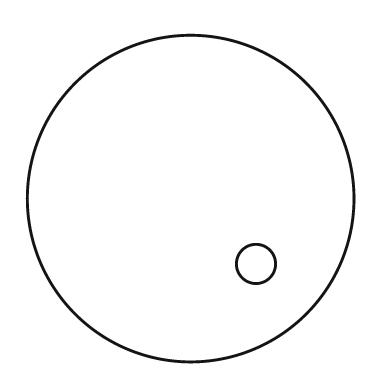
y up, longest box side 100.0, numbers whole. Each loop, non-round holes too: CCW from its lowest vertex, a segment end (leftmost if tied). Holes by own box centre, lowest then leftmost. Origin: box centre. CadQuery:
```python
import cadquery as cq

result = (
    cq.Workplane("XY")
    .moveTo(0.0, 0.0)
    .circle(50.0)
    .moveTo(20.0, -20.0)
    .circle(6.0)
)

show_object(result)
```